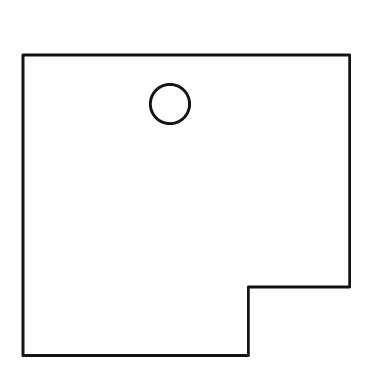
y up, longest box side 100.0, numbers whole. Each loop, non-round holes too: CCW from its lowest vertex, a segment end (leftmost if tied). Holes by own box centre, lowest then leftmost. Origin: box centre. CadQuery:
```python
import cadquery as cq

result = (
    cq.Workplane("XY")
    .moveTo(-50.0, -46.0)
    .lineTo(19.0, -46.0)
    .lineTo(19.0, -25.0)
    .lineTo(50.0, -25.0)
    .lineTo(50.0, 46.0)
    .lineTo(-50.0, 46.0)
    .close()
    .moveTo(-5.0, 31.0)
    .circle(6.0)
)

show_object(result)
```